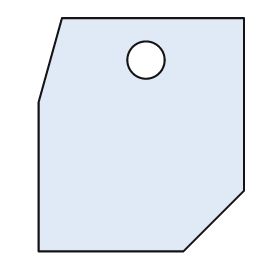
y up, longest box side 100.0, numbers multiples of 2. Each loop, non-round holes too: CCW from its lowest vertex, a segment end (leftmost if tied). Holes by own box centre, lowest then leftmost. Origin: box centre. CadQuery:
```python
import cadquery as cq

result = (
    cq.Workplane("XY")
    .moveTo(-44.0, -50.0)
    .lineTo(18.0, -50.0)
    .lineTo(44.0, -24.0)
    .lineTo(44.0, 50.0)
    .lineTo(-34.0, 50.0)
    .lineTo(-44.0, 14.0)
    .close()
    .moveTo(2.0, 32.0)
    .circle(8.0)
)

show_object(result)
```